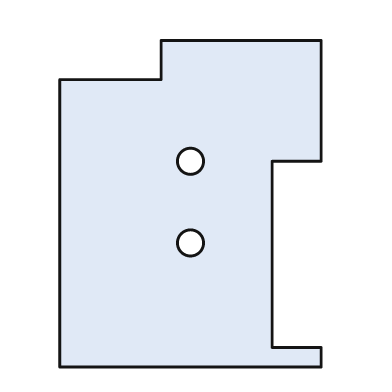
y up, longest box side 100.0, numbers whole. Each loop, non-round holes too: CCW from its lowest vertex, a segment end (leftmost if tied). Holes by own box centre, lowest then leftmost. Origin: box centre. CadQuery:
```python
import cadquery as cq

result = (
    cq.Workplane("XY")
    .moveTo(-40.0, -50.0)
    .lineTo(40.0, -50.0)
    .lineTo(40.0, -44.0)
    .lineTo(25.0, -44.0)
    .lineTo(25.0, 13.0)
    .lineTo(40.0, 13.0)
    .lineTo(40.0, 50.0)
    .lineTo(-9.0, 50.0)
    .lineTo(-9.0, 38.0)
    .lineTo(-40.0, 38.0)
    .close()
    .moveTo(0.0, -12.0)
    .circle(4.0)
    .moveTo(0.0, 13.0)
    .circle(4.0)
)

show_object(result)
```